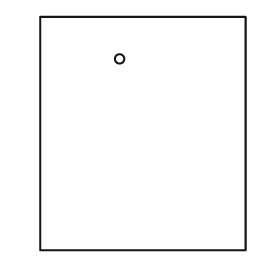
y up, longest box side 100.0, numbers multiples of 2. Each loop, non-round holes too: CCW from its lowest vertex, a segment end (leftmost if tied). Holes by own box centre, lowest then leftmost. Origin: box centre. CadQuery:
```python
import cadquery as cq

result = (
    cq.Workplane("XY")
    .moveTo(-44.0, -50.0)
    .lineTo(44.0, -50.0)
    .lineTo(44.0, 50.0)
    .lineTo(-44.0, 50.0)
    .close()
    .moveTo(-10.0, 32.0)
    .circle(2.0)
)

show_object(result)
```